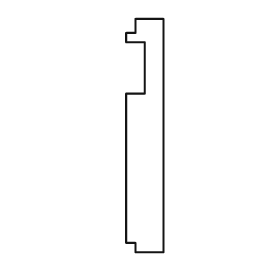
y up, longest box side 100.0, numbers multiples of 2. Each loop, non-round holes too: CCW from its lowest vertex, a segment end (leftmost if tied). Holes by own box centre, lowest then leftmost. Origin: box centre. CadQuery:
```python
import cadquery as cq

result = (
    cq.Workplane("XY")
    .moveTo(-4.0, -50.0)
    .lineTo(8.0, -50.0)
    .lineTo(8.0, 50.0)
    .lineTo(-4.0, 50.0)
    .lineTo(-4.0, 44.0)
    .lineTo(-8.0, 44.0)
    .lineTo(-8.0, 40.0)
    .lineTo(0.0, 40.0)
    .lineTo(0.0, 18.0)
    .lineTo(-8.0, 18.0)
    .lineTo(-8.0, -46.0)
    .lineTo(-4.0, -46.0)
    .close()
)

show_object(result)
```